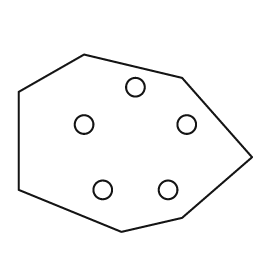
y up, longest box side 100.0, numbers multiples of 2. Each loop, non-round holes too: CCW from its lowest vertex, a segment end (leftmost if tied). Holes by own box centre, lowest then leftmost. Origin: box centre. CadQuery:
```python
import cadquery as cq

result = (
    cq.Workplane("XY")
    .moveTo(-6.0, -38.0)
    .lineTo(20.0, -32.0)
    .lineTo(50.0, -6.0)
    .lineTo(20.0, 28.0)
    .lineTo(-22.0, 38.0)
    .lineTo(-50.0, 22.0)
    .lineTo(-50.0, -20.0)
    .close()
    .moveTo(-14.0, -20.0)
    .circle(4.0)
    .moveTo(14.0, -20.0)
    .circle(4.0)
    .moveTo(-22.0, 8.0)
    .circle(4.0)
    .moveTo(22.0, 8.0)
    .circle(4.0)
    .moveTo(0.0, 24.0)
    .circle(4.0)
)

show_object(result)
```